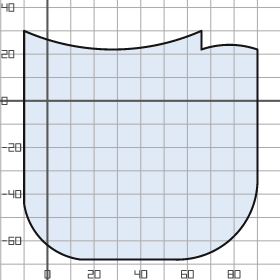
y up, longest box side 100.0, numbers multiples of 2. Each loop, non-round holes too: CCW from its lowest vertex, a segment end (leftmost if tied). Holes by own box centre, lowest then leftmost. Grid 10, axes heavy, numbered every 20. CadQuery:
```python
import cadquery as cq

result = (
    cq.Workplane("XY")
    .moveTo(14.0, -68.0)
    .lineTo(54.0, -68.0)
    .threePointArc((80.0, -58.0), (90.0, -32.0))
    .lineTo(90.0, 22.0)
    .threePointArc((78.0, 24.0), (66.0, 22.0))
    .lineTo(66.0, 30.0)
    .threePointArc((28.0, 22.0), (-10.0, 30.0))
    .lineTo(-10.0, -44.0)
    .threePointArc((-2.0, -60.0), (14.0, -68.0))
    .close()
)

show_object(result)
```